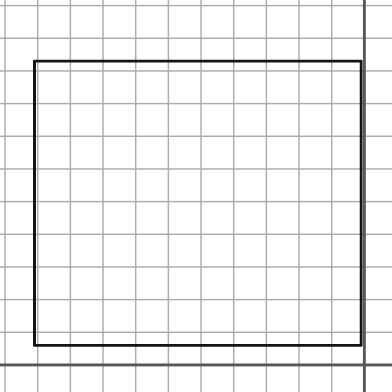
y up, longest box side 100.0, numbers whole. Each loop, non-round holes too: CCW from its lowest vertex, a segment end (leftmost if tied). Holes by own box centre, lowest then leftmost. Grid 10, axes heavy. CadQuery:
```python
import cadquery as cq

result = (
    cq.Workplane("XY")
    .moveTo(-101.0, 6.0)
    .lineTo(-1.0, 6.0)
    .lineTo(-1.0, 93.0)
    .lineTo(-101.0, 93.0)
    .close()
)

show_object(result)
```